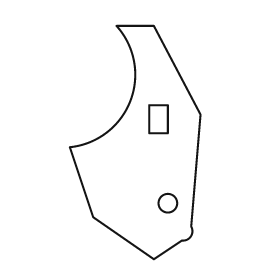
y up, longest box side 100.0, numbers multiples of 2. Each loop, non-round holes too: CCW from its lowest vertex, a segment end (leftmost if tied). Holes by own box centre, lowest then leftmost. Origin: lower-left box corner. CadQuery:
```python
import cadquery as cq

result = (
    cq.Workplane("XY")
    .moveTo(36.0, 0.0)
    .lineTo(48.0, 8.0)
    .threePointArc((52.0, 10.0), (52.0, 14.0))
    .lineTo(56.0, 62.0)
    .lineTo(36.0, 100.0)
    .lineTo(20.0, 100.0)
    .threePointArc((26.0, 68.0), (0.0, 48.0))
    .lineTo(10.0, 18.0)
    .close()
    .moveTo(42.0, 24.0)
    .circle(4.0)
    .moveTo(34.0, 54.0)
    .lineTo(42.0, 54.0)
    .lineTo(42.0, 66.0)
    .lineTo(34.0, 66.0)
    .close()
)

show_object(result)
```